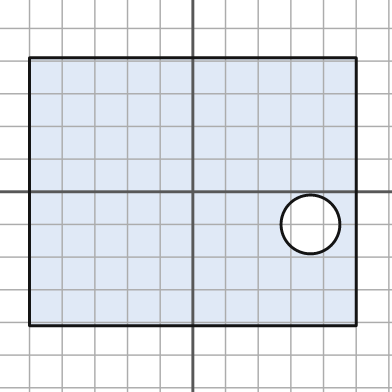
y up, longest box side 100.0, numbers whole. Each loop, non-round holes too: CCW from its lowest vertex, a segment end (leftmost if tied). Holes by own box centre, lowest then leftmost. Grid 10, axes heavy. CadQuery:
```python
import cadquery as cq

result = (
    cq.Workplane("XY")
    .moveTo(-50.0, -41.0)
    .lineTo(50.0, -41.0)
    .lineTo(50.0, 41.0)
    .lineTo(-50.0, 41.0)
    .close()
    .moveTo(36.0, -10.0)
    .circle(9.0)
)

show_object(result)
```